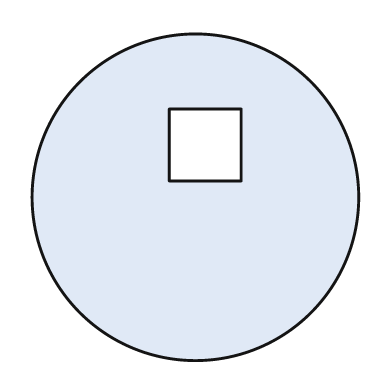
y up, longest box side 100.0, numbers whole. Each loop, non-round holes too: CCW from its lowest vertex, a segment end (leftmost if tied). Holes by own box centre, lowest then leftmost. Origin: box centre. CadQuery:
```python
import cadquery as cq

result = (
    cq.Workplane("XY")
    .moveTo(0.0, 0.0)
    .circle(50.0)
    .moveTo(-8.0, 5.0)
    .lineTo(14.0, 5.0)
    .lineTo(14.0, 27.0)
    .lineTo(-8.0, 27.0)
    .close()
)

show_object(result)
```